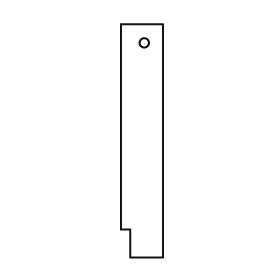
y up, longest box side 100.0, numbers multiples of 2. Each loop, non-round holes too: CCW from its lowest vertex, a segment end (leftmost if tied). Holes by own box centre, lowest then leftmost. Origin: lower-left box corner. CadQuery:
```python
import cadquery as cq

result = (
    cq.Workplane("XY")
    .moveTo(4.0, 0.0)
    .lineTo(18.0, 0.0)
    .lineTo(18.0, 100.0)
    .lineTo(0.0, 100.0)
    .lineTo(0.0, 12.0)
    .lineTo(4.0, 12.0)
    .close()
    .moveTo(10.0, 92.0)
    .circle(2.0)
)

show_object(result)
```